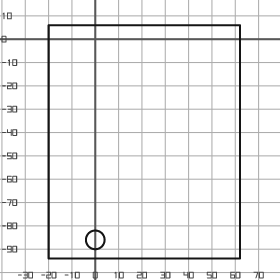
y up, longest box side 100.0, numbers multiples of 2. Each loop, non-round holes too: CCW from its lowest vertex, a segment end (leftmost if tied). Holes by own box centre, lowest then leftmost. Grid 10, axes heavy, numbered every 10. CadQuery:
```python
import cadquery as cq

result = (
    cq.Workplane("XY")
    .moveTo(-20.0, -94.0)
    .lineTo(62.0, -94.0)
    .lineTo(62.0, 6.0)
    .lineTo(-20.0, 6.0)
    .close()
    .moveTo(0.0, -86.0)
    .circle(4.0)
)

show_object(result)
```